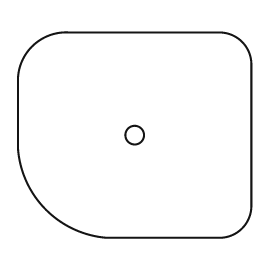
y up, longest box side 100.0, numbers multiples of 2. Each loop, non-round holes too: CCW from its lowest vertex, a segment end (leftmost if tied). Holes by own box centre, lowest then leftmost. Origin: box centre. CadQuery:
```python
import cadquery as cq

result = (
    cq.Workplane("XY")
    .moveTo(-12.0, -44.0)
    .lineTo(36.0, -44.0)
    .threePointArc((46.0, -40.0), (50.0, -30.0))
    .lineTo(50.0, 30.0)
    .threePointArc((46.0, 40.0), (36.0, 44.0))
    .lineTo(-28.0, 44.0)
    .threePointArc((-44.0, 38.0), (-50.0, 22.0))
    .lineTo(-50.0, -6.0)
    .threePointArc((-38.0, -32.0), (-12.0, -44.0))
    .close()
    .moveTo(0.0, 0.0)
    .circle(4.0)
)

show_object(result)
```